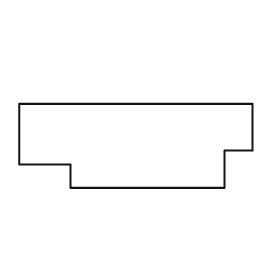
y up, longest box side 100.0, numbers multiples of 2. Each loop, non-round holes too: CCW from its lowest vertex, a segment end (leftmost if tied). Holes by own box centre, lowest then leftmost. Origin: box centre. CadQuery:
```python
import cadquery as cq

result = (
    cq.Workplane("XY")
    .moveTo(-28.0, -18.0)
    .lineTo(38.0, -18.0)
    .lineTo(38.0, -2.0)
    .lineTo(50.0, -2.0)
    .lineTo(50.0, 18.0)
    .lineTo(-50.0, 18.0)
    .lineTo(-50.0, -8.0)
    .lineTo(-28.0, -8.0)
    .close()
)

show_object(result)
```